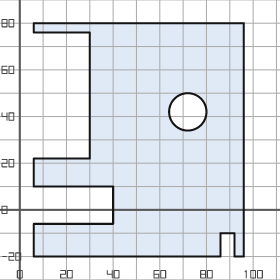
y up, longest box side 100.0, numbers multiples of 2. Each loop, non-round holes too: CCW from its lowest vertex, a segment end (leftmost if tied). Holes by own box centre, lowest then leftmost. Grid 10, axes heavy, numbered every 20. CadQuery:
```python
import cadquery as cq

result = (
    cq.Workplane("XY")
    .moveTo(6.0, -20.0)
    .lineTo(86.0, -20.0)
    .lineTo(86.0, -10.0)
    .lineTo(92.0, -10.0)
    .lineTo(92.0, -20.0)
    .lineTo(96.0, -20.0)
    .lineTo(96.0, 80.0)
    .lineTo(6.0, 80.0)
    .lineTo(6.0, 76.0)
    .lineTo(30.0, 76.0)
    .lineTo(30.0, 22.0)
    .lineTo(6.0, 22.0)
    .lineTo(6.0, 10.0)
    .lineTo(40.0, 10.0)
    .lineTo(40.0, -6.0)
    .lineTo(6.0, -6.0)
    .close()
    .moveTo(72.0, 42.0)
    .circle(8.0)
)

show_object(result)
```